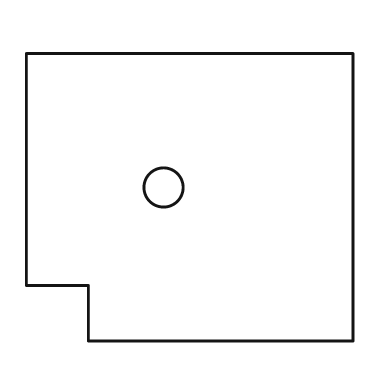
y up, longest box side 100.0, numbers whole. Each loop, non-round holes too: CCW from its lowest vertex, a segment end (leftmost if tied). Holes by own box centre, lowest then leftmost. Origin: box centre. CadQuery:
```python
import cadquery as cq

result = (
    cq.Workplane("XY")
    .moveTo(-31.0, -44.0)
    .lineTo(50.0, -44.0)
    .lineTo(50.0, 44.0)
    .lineTo(-50.0, 44.0)
    .lineTo(-50.0, -27.0)
    .lineTo(-31.0, -27.0)
    .close()
    .moveTo(-8.0, 3.0)
    .circle(6.0)
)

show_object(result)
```